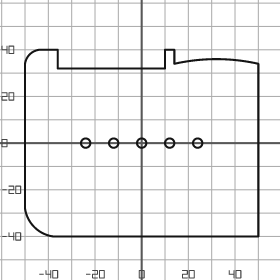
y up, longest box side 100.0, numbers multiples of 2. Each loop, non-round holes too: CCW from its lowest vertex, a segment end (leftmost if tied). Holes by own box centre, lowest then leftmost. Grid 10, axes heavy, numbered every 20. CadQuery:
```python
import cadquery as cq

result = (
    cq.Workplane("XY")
    .moveTo(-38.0, -40.0)
    .lineTo(50.0, -40.0)
    .lineTo(50.0, 34.0)
    .threePointArc((32.0, 36.0), (14.0, 34.0))
    .lineTo(14.0, 40.0)
    .lineTo(10.0, 40.0)
    .lineTo(10.0, 32.0)
    .lineTo(-36.0, 32.0)
    .lineTo(-36.0, 40.0)
    .lineTo(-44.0, 40.0)
    .threePointArc((-48.0, 38.0), (-50.0, 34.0))
    .lineTo(-50.0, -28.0)
    .threePointArc((-46.0, -36.0), (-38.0, -40.0))
    .close()
    .moveTo(-24.0, 0.0)
    .circle(2.0)
    .moveTo(-12.0, 0.0)
    .circle(2.0)
    .moveTo(0.0, 0.0)
    .circle(2.0)
    .moveTo(12.0, 0.0)
    .circle(2.0)
    .moveTo(24.0, 0.0)
    .circle(2.0)
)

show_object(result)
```